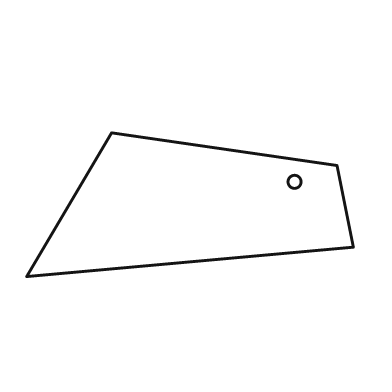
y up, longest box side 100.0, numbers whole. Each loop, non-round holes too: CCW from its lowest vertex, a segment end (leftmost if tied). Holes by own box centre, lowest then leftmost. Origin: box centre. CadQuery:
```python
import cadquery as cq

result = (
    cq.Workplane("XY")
    .moveTo(-50.0, -22.0)
    .lineTo(50.0, -13.0)
    .lineTo(45.0, 12.0)
    .lineTo(-24.0, 22.0)
    .close()
    .moveTo(32.0, 7.0)
    .circle(2.0)
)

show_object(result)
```